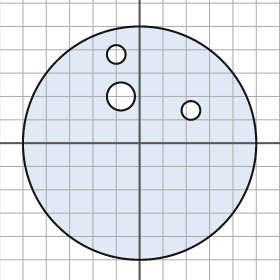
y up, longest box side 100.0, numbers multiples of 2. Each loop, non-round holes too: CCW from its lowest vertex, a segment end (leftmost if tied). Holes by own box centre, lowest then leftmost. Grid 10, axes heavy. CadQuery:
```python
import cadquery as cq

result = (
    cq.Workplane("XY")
    .moveTo(0.0, 0.0)
    .circle(50.0)
    .moveTo(22.0, 14.0)
    .circle(4.0)
    .moveTo(-8.0, 20.0)
    .circle(6.0)
    .moveTo(-10.0, 38.0)
    .circle(4.0)
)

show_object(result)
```